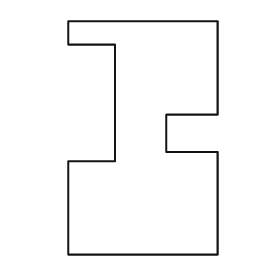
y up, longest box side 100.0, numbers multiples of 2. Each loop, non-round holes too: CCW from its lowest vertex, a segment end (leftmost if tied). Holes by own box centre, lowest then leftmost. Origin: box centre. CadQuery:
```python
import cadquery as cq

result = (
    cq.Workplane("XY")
    .moveTo(-32.0, -50.0)
    .lineTo(32.0, -50.0)
    .lineTo(32.0, -6.0)
    .lineTo(10.0, -6.0)
    .lineTo(10.0, 10.0)
    .lineTo(32.0, 10.0)
    .lineTo(32.0, 50.0)
    .lineTo(-32.0, 50.0)
    .lineTo(-32.0, 40.0)
    .lineTo(-12.0, 40.0)
    .lineTo(-12.0, -10.0)
    .lineTo(-32.0, -10.0)
    .close()
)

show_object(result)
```